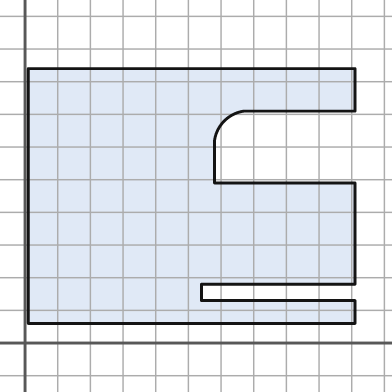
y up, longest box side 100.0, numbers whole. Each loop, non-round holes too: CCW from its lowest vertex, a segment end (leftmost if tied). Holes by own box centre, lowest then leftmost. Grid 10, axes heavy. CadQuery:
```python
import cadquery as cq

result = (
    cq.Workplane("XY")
    .moveTo(1.0, 6.0)
    .lineTo(101.0, 6.0)
    .lineTo(101.0, 13.0)
    .lineTo(54.0, 13.0)
    .lineTo(54.0, 18.0)
    .lineTo(101.0, 18.0)
    .lineTo(101.0, 49.0)
    .lineTo(58.0, 49.0)
    .lineTo(58.0, 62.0)
    .threePointArc((61.0, 68.0), (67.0, 71.0))
    .lineTo(101.0, 71.0)
    .lineTo(101.0, 84.0)
    .lineTo(1.0, 84.0)
    .close()
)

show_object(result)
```